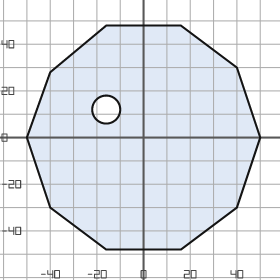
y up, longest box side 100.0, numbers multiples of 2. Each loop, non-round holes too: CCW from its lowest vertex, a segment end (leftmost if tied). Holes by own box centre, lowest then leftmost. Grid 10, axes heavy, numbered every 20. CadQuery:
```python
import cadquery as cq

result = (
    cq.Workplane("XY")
    .moveTo(-16.0, -48.0)
    .lineTo(16.0, -48.0)
    .lineTo(40.0, -30.0)
    .lineTo(50.0, 0.0)
    .lineTo(40.0, 30.0)
    .lineTo(16.0, 48.0)
    .lineTo(-16.0, 48.0)
    .lineTo(-40.0, 28.0)
    .lineTo(-50.0, 0.0)
    .lineTo(-40.0, -30.0)
    .close()
    .moveTo(-16.0, 12.0)
    .circle(6.0)
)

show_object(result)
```